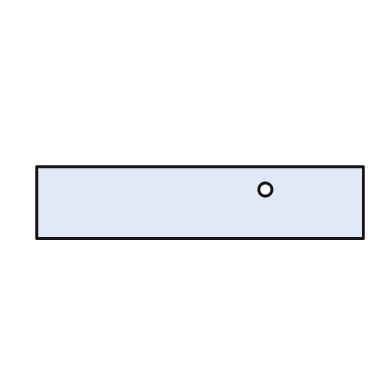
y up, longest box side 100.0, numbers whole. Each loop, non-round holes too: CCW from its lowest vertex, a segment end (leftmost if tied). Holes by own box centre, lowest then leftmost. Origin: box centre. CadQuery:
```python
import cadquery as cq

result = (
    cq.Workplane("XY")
    .moveTo(-50.0, -11.0)
    .lineTo(50.0, -11.0)
    .lineTo(50.0, 11.0)
    .lineTo(-50.0, 11.0)
    .close()
    .moveTo(20.0, 4.0)
    .circle(2.0)
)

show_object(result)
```